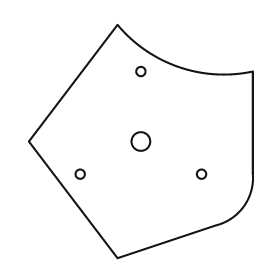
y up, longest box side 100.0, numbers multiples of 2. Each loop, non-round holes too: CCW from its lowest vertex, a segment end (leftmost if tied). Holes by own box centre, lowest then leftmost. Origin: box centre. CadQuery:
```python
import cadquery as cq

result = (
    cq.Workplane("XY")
    .moveTo(-10.0, -50.0)
    .lineTo(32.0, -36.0)
    .threePointArc((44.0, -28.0), (48.0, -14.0))
    .lineTo(48.0, 30.0)
    .threePointArc((16.0, 32.0), (-10.0, 50.0))
    .lineTo(-48.0, 0.0)
    .close()
    .moveTo(-26.0, -14.0)
    .circle(2.0)
    .moveTo(26.0, -14.0)
    .circle(2.0)
    .moveTo(0.0, 0.0)
    .circle(4.0)
    .moveTo(0.0, 30.0)
    .circle(2.0)
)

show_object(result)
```